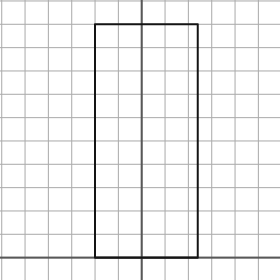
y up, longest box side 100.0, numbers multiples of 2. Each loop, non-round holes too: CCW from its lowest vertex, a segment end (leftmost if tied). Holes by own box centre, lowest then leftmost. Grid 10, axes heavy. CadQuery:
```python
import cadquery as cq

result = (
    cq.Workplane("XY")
    .moveTo(-20.0, 0.0)
    .lineTo(24.0, 0.0)
    .lineTo(24.0, 100.0)
    .lineTo(-20.0, 100.0)
    .close()
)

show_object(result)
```